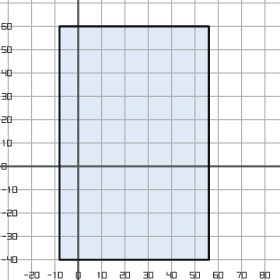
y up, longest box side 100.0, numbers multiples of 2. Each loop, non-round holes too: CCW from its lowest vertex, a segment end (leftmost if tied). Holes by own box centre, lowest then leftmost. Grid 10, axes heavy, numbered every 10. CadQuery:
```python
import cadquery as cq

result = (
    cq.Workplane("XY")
    .moveTo(-8.0, -40.0)
    .lineTo(56.0, -40.0)
    .lineTo(56.0, 60.0)
    .lineTo(-8.0, 60.0)
    .close()
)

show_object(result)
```